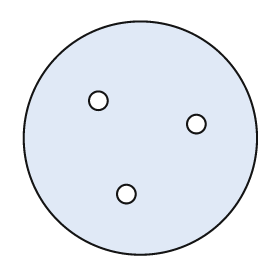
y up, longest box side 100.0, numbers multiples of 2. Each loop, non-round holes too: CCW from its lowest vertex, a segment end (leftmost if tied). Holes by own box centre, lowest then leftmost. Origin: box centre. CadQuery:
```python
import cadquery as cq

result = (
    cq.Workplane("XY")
    .moveTo(0.0, 0.0)
    .circle(50.0)
    .moveTo(-6.0, -24.0)
    .circle(4.0)
    .moveTo(24.0, 6.0)
    .circle(4.0)
    .moveTo(-18.0, 16.0)
    .circle(4.0)
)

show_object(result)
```